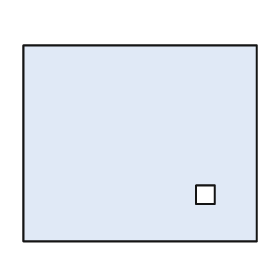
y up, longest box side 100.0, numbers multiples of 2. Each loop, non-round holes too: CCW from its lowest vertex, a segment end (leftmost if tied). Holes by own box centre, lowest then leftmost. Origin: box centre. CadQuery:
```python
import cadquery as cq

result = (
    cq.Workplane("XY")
    .moveTo(-50.0, -42.0)
    .lineTo(50.0, -42.0)
    .lineTo(50.0, 42.0)
    .lineTo(-50.0, 42.0)
    .close()
    .moveTo(24.0, -26.0)
    .lineTo(32.0, -26.0)
    .lineTo(32.0, -18.0)
    .lineTo(24.0, -18.0)
    .close()
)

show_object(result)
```